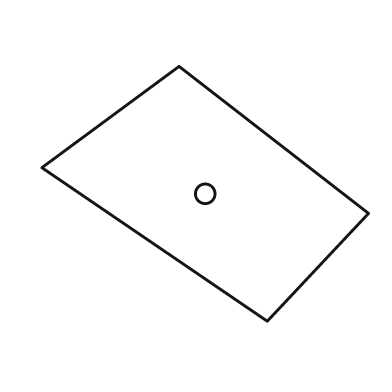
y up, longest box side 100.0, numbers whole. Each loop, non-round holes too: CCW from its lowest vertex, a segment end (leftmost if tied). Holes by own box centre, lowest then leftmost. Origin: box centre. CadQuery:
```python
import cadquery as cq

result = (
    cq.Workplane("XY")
    .moveTo(19.0, -39.0)
    .lineTo(50.0, -6.0)
    .lineTo(-8.0, 39.0)
    .lineTo(-50.0, 8.0)
    .close()
    .moveTo(0.0, 0.0)
    .circle(3.0)
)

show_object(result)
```